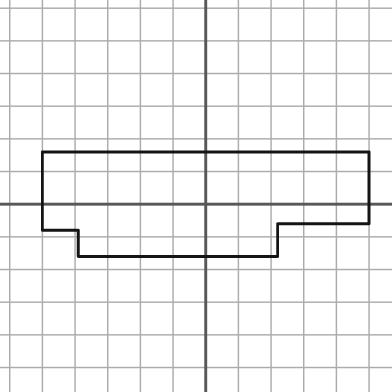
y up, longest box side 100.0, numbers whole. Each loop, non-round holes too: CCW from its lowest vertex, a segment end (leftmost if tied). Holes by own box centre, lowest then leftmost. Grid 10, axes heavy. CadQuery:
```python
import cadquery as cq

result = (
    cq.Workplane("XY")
    .moveTo(-39.0, -16.0)
    .lineTo(22.0, -16.0)
    .lineTo(22.0, -6.0)
    .lineTo(50.0, -6.0)
    .lineTo(50.0, 16.0)
    .lineTo(-50.0, 16.0)
    .lineTo(-50.0, -8.0)
    .lineTo(-39.0, -8.0)
    .close()
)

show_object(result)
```